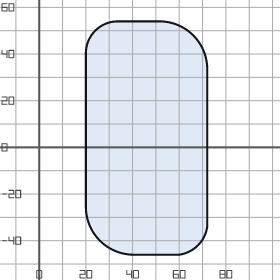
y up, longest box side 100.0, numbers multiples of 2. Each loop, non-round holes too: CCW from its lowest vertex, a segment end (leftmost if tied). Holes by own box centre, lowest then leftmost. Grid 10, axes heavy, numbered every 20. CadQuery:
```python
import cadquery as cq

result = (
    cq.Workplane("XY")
    .moveTo(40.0, -46.0)
    .lineTo(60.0, -46.0)
    .threePointArc((68.0, -42.0), (72.0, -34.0))
    .lineTo(72.0, 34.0)
    .threePointArc((66.0, 48.0), (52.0, 54.0))
    .lineTo(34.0, 54.0)
    .threePointArc((24.0, 50.0), (20.0, 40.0))
    .lineTo(20.0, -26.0)
    .threePointArc((26.0, -40.0), (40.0, -46.0))
    .close()
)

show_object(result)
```